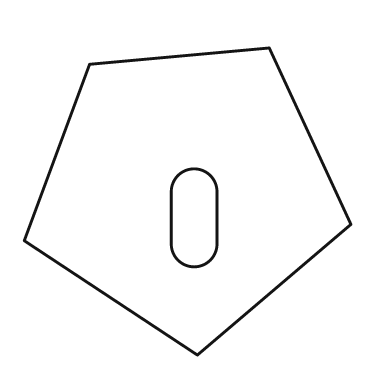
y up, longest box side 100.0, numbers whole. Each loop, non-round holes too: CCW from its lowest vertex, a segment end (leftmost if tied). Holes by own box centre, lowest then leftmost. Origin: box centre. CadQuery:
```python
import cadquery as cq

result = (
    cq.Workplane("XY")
    .moveTo(3.0, -47.0)
    .lineTo(50.0, -7.0)
    .lineTo(25.0, 47.0)
    .lineTo(-30.0, 42.0)
    .lineTo(-50.0, -12.0)
    .close()
    .moveTo(-5.0, -13.0)
    .threePointArc((2.0, -20.0), (9.0, -13.0))
    .lineTo(9.0, 3.0)
    .threePointArc((2.0, 10.0), (-5.0, 3.0))
    .close()
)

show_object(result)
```